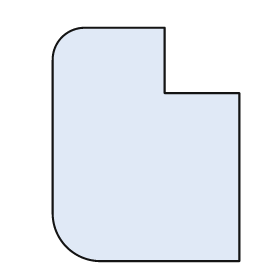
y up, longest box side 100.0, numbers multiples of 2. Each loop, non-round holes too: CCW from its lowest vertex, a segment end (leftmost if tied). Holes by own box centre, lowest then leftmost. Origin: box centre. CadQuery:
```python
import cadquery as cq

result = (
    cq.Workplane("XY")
    .moveTo(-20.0, -50.0)
    .lineTo(40.0, -50.0)
    .lineTo(40.0, 22.0)
    .lineTo(8.0, 22.0)
    .lineTo(8.0, 50.0)
    .lineTo(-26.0, 50.0)
    .threePointArc((-36.0, 46.0), (-40.0, 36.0))
    .lineTo(-40.0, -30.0)
    .threePointArc((-34.0, -44.0), (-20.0, -50.0))
    .close()
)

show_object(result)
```